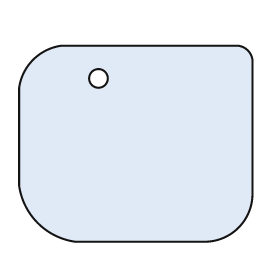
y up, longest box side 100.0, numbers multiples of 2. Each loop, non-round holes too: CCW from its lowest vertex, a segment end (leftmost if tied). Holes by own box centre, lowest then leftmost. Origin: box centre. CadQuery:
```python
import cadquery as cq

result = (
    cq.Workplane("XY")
    .moveTo(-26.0, -42.0)
    .lineTo(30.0, -42.0)
    .threePointArc((44.0, -36.0), (50.0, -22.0))
    .lineTo(50.0, 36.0)
    .threePointArc((48.0, 40.0), (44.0, 42.0))
    .lineTo(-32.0, 42.0)
    .threePointArc((-44.0, 36.0), (-50.0, 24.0))
    .lineTo(-50.0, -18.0)
    .threePointArc((-42.0, -34.0), (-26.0, -42.0))
    .close()
    .moveTo(-16.0, 28.0)
    .circle(4.0)
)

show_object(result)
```